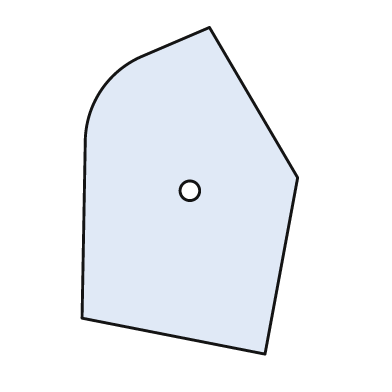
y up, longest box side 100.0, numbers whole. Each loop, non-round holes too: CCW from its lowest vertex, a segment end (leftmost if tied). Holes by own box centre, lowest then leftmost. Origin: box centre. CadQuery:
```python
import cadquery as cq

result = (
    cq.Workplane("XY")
    .moveTo(23.0, -50.0)
    .lineTo(33.0, 4.0)
    .lineTo(6.0, 50.0)
    .lineTo(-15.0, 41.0)
    .threePointArc((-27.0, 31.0), (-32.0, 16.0))
    .lineTo(-33.0, -39.0)
    .close()
    .moveTo(0.0, 0.0)
    .circle(3.0)
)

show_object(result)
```